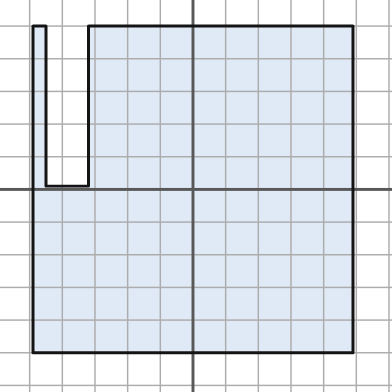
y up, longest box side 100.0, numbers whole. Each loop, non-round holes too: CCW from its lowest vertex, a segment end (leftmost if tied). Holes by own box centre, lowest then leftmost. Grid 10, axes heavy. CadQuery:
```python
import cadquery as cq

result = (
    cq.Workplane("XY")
    .moveTo(-49.0, -50.0)
    .lineTo(49.0, -50.0)
    .lineTo(49.0, 50.0)
    .lineTo(-32.0, 50.0)
    .lineTo(-32.0, 1.0)
    .lineTo(-45.0, 1.0)
    .lineTo(-45.0, 50.0)
    .lineTo(-49.0, 50.0)
    .close()
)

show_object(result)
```